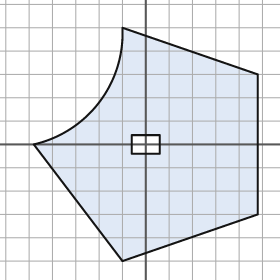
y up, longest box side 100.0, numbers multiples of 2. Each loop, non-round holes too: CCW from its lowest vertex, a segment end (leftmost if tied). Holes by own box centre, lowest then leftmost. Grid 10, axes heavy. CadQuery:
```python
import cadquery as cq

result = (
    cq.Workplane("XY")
    .moveTo(-10.0, -50.0)
    .lineTo(48.0, -30.0)
    .lineTo(48.0, 30.0)
    .lineTo(-10.0, 50.0)
    .threePointArc((-20.0, 18.0), (-48.0, 0.0))
    .close()
    .moveTo(-6.0, -4.0)
    .lineTo(6.0, -4.0)
    .lineTo(6.0, 4.0)
    .lineTo(-6.0, 4.0)
    .close()
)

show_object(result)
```